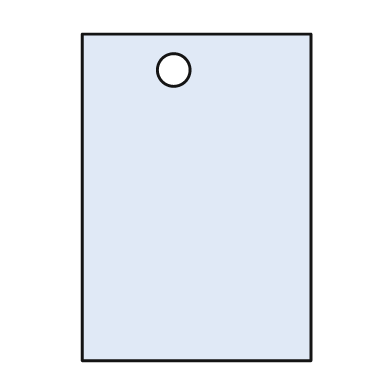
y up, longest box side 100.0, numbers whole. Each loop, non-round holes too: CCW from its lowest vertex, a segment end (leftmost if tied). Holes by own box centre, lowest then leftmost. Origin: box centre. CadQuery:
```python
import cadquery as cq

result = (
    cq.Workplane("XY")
    .moveTo(-35.0, -50.0)
    .lineTo(35.0, -50.0)
    .lineTo(35.0, 50.0)
    .lineTo(-35.0, 50.0)
    .close()
    .moveTo(-7.0, 39.0)
    .circle(5.0)
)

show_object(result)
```